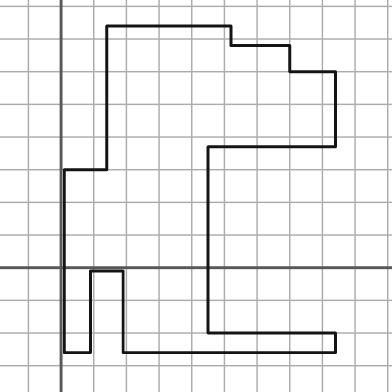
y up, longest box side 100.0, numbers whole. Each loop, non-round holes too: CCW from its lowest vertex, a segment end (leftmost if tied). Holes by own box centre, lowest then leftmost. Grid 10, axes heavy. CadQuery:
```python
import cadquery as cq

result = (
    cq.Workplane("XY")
    .moveTo(1.0, -26.0)
    .lineTo(9.0, -26.0)
    .lineTo(9.0, -1.0)
    .lineTo(19.0, -1.0)
    .lineTo(19.0, -26.0)
    .lineTo(84.0, -26.0)
    .lineTo(84.0, -20.0)
    .lineTo(45.0, -20.0)
    .lineTo(45.0, 37.0)
    .lineTo(84.0, 37.0)
    .lineTo(84.0, 60.0)
    .lineTo(70.0, 60.0)
    .lineTo(70.0, 68.0)
    .lineTo(52.0, 68.0)
    .lineTo(52.0, 74.0)
    .lineTo(14.0, 74.0)
    .lineTo(14.0, 30.0)
    .lineTo(1.0, 30.0)
    .close()
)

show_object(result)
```